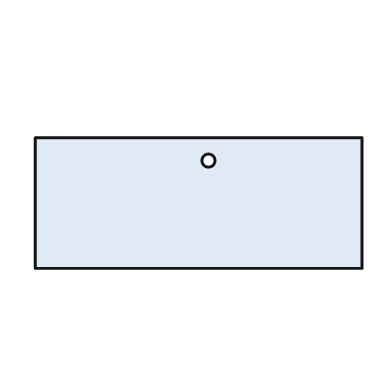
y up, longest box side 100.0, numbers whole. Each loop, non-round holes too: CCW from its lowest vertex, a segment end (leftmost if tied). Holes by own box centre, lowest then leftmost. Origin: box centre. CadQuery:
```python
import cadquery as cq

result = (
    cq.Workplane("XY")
    .moveTo(-50.0, -20.0)
    .lineTo(50.0, -20.0)
    .lineTo(50.0, 20.0)
    .lineTo(-50.0, 20.0)
    .close()
    .moveTo(3.0, 13.0)
    .circle(2.0)
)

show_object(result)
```